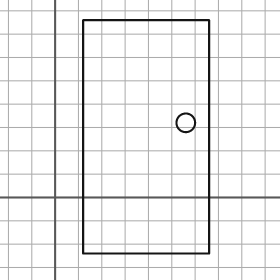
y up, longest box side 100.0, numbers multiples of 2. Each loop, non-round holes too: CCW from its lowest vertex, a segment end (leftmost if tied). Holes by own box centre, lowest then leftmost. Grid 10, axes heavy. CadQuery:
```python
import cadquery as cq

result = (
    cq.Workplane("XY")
    .moveTo(12.0, -24.0)
    .lineTo(66.0, -24.0)
    .lineTo(66.0, 76.0)
    .lineTo(12.0, 76.0)
    .close()
    .moveTo(56.0, 32.0)
    .circle(4.0)
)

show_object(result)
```